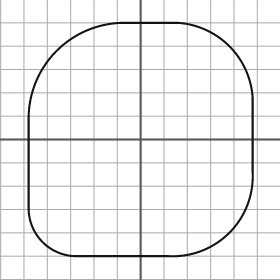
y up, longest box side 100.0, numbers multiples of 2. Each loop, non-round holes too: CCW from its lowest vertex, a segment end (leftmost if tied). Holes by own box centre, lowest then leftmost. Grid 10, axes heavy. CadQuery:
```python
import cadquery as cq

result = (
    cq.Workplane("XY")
    .moveTo(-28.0, -50.0)
    .lineTo(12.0, -50.0)
    .threePointArc((38.0, -40.0), (48.0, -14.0))
    .lineTo(48.0, 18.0)
    .threePointArc((38.0, 40.0), (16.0, 50.0))
    .lineTo(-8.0, 50.0)
    .threePointArc((-36.0, 38.0), (-48.0, 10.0))
    .lineTo(-48.0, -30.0)
    .threePointArc((-42.0, -44.0), (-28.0, -50.0))
    .close()
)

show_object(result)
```